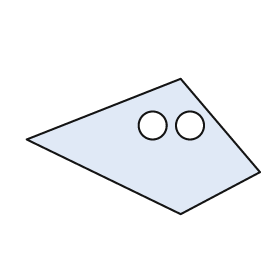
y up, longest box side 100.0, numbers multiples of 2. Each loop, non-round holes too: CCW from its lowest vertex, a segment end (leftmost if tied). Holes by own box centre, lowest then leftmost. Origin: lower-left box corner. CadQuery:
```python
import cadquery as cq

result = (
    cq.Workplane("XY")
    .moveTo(66.0, 0.0)
    .lineTo(100.0, 18.0)
    .lineTo(66.0, 58.0)
    .lineTo(0.0, 32.0)
    .close()
    .moveTo(54.0, 38.0)
    .circle(6.0)
    .moveTo(70.0, 38.0)
    .circle(6.0)
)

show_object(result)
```